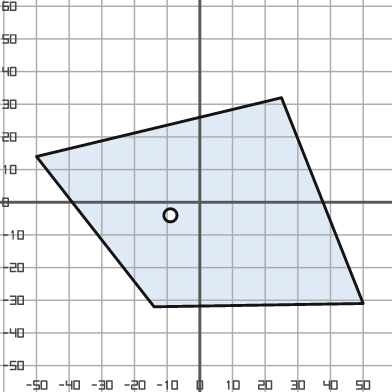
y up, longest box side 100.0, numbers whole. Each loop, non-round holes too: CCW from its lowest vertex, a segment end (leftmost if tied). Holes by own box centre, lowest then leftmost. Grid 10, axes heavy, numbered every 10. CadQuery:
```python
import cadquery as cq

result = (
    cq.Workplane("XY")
    .moveTo(-14.0, -32.0)
    .lineTo(50.0, -31.0)
    .lineTo(25.0, 32.0)
    .lineTo(-50.0, 14.0)
    .close()
    .moveTo(-9.0, -4.0)
    .circle(2.0)
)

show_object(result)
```